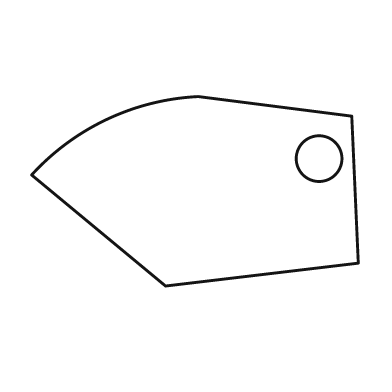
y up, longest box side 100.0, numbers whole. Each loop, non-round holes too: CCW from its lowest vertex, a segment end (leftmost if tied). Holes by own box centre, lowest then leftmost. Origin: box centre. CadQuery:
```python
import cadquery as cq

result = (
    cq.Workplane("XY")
    .moveTo(-9.0, -29.0)
    .lineTo(50.0, -22.0)
    .lineTo(48.0, 23.0)
    .lineTo(1.0, 29.0)
    .threePointArc((-27.0, 22.0), (-50.0, 5.0))
    .close()
    .moveTo(38.0, 10.0)
    .circle(7.0)
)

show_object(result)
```